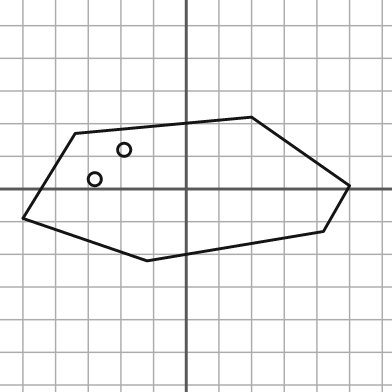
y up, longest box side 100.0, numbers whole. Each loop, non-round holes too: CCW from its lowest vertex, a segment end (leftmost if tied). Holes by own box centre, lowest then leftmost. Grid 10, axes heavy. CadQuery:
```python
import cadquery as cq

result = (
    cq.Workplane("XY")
    .moveTo(-12.0, -22.0)
    .lineTo(42.0, -13.0)
    .lineTo(50.0, 1.0)
    .lineTo(20.0, 22.0)
    .lineTo(-34.0, 17.0)
    .lineTo(-50.0, -9.0)
    .close()
    .moveTo(-28.0, 3.0)
    .circle(2.0)
    .moveTo(-19.0, 12.0)
    .circle(2.0)
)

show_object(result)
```